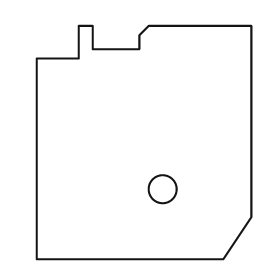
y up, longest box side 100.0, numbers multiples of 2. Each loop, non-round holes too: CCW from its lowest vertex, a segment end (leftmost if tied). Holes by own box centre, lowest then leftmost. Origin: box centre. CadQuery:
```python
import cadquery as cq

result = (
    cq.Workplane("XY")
    .moveTo(-46.0, -50.0)
    .lineTo(34.0, -50.0)
    .lineTo(46.0, -32.0)
    .lineTo(46.0, 50.0)
    .lineTo(2.0, 50.0)
    .lineTo(-2.0, 46.0)
    .lineTo(-2.0, 40.0)
    .lineTo(-22.0, 40.0)
    .lineTo(-22.0, 50.0)
    .lineTo(-28.0, 50.0)
    .lineTo(-28.0, 36.0)
    .lineTo(-46.0, 36.0)
    .close()
    .moveTo(8.0, -20.0)
    .circle(6.0)
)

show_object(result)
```